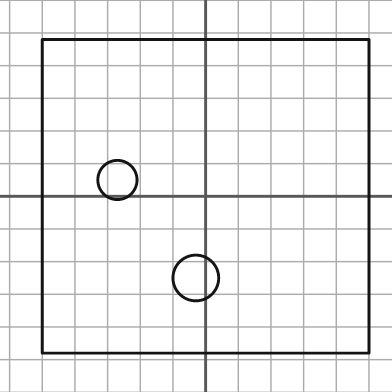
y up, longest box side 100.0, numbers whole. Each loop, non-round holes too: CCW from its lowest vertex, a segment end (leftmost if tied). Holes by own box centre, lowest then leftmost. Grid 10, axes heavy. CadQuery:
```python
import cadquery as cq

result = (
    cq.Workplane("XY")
    .moveTo(-50.0, -48.0)
    .lineTo(50.0, -48.0)
    .lineTo(50.0, 48.0)
    .lineTo(-50.0, 48.0)
    .close()
    .moveTo(-3.0, -25.0)
    .circle(7.0)
    .moveTo(-27.0, 5.0)
    .circle(6.0)
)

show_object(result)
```